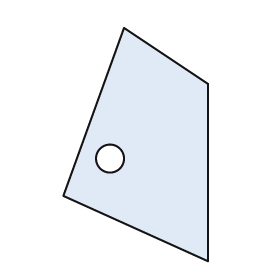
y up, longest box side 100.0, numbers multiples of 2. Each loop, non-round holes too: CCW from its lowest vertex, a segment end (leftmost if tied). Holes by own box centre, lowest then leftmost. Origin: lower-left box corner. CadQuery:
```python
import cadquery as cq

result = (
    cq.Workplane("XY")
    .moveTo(62.0, 0.0)
    .lineTo(62.0, 76.0)
    .lineTo(26.0, 100.0)
    .lineTo(0.0, 28.0)
    .close()
    .moveTo(20.0, 44.0)
    .circle(6.0)
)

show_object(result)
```